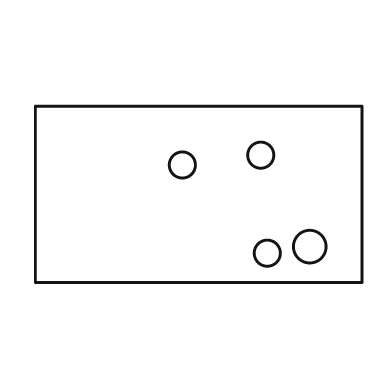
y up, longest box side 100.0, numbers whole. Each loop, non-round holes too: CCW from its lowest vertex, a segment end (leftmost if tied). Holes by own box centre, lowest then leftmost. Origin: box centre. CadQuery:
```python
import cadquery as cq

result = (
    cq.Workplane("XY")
    .moveTo(-50.0, -27.0)
    .lineTo(50.0, -27.0)
    .lineTo(50.0, 27.0)
    .lineTo(-50.0, 27.0)
    .close()
    .moveTo(21.0, -18.0)
    .circle(4.0)
    .moveTo(34.0, -16.0)
    .circle(5.0)
    .moveTo(-5.0, 9.0)
    .circle(4.0)
    .moveTo(19.0, 12.0)
    .circle(4.0)
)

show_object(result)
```